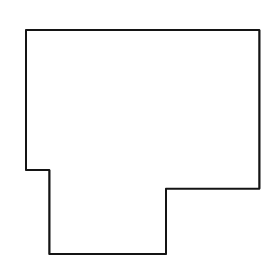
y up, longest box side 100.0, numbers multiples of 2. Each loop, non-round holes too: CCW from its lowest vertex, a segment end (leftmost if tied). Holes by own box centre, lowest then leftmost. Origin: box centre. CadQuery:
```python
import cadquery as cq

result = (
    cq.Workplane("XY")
    .moveTo(-40.0, -48.0)
    .lineTo(10.0, -48.0)
    .lineTo(10.0, -20.0)
    .lineTo(50.0, -20.0)
    .lineTo(50.0, 48.0)
    .lineTo(-50.0, 48.0)
    .lineTo(-50.0, -12.0)
    .lineTo(-40.0, -12.0)
    .close()
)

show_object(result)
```